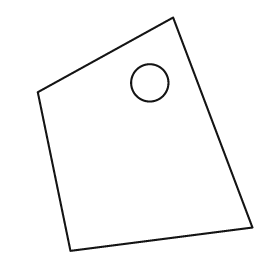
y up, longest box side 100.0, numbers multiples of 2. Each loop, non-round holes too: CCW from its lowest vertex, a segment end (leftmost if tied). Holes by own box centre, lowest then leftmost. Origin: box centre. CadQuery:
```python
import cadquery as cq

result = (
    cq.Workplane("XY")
    .moveTo(-32.0, -50.0)
    .lineTo(46.0, -40.0)
    .lineTo(12.0, 50.0)
    .lineTo(-46.0, 18.0)
    .close()
    .moveTo(2.0, 22.0)
    .circle(8.0)
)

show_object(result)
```